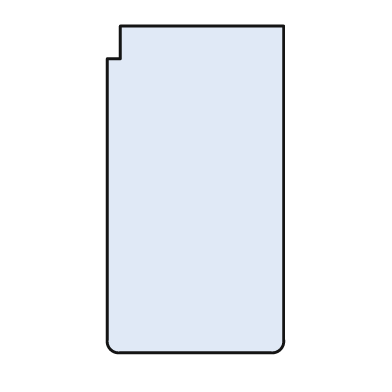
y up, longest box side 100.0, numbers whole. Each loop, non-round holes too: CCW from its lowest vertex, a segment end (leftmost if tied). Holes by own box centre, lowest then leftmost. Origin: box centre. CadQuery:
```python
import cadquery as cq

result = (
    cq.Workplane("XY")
    .moveTo(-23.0, -50.0)
    .lineTo(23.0, -50.0)
    .threePointArc((26.0, -49.0), (27.0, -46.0))
    .lineTo(27.0, 50.0)
    .lineTo(-23.0, 50.0)
    .lineTo(-23.0, 40.0)
    .lineTo(-27.0, 40.0)
    .lineTo(-27.0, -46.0)
    .threePointArc((-26.0, -49.0), (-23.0, -50.0))
    .close()
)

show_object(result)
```